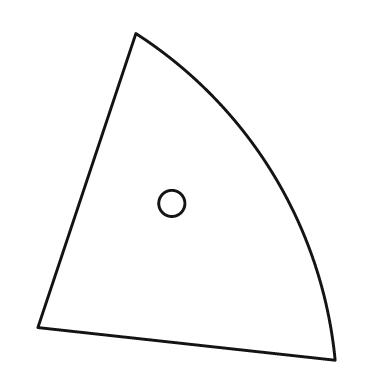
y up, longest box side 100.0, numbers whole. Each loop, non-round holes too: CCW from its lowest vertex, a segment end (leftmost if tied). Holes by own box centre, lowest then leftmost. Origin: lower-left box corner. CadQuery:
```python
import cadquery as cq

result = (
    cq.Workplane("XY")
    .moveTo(91.0, 0.0)
    .threePointArc((72.0, 57.0), (30.0, 100.0))
    .lineTo(0.0, 10.0)
    .close()
    .moveTo(41.0, 48.0)
    .circle(4.0)
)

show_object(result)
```